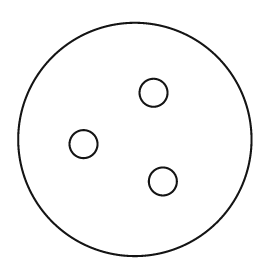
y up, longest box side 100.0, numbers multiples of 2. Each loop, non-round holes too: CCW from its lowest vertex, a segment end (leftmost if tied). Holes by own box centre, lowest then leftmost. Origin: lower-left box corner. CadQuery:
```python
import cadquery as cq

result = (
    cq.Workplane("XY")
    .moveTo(50.0, 50.0)
    .circle(50.0)
    .moveTo(62.0, 32.0)
    .circle(6.0)
    .moveTo(28.0, 48.0)
    .circle(6.0)
    .moveTo(58.0, 70.0)
    .circle(6.0)
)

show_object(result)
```